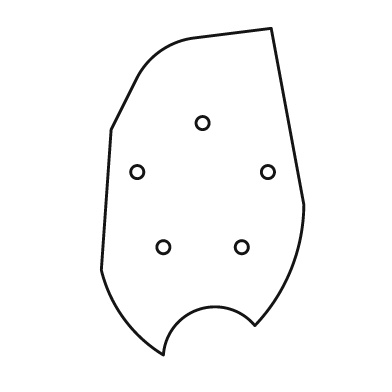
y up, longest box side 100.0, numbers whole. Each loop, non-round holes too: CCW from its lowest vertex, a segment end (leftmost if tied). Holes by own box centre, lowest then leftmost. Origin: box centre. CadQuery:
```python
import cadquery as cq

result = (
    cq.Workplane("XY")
    .moveTo(-12.0, -50.0)
    .threePointArc((-1.0, -36.0), (16.0, -41.0))
    .threePointArc((27.0, -24.0), (31.0, -4.0))
    .lineTo(21.0, 50.0)
    .lineTo(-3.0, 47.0)
    .threePointArc((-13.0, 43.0), (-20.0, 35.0))
    .lineTo(-28.0, 19.0)
    .lineTo(-31.0, -24.0)
    .threePointArc((-24.0, -39.0), (-12.0, -50.0))
    .close()
    .moveTo(-12.0, -17.0)
    .circle(2.0)
    .moveTo(12.0, -17.0)
    .circle(2.0)
    .moveTo(-20.0, 6.0)
    .circle(2.0)
    .moveTo(20.0, 6.0)
    .circle(2.0)
    .moveTo(0.0, 21.0)
    .circle(2.0)
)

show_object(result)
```